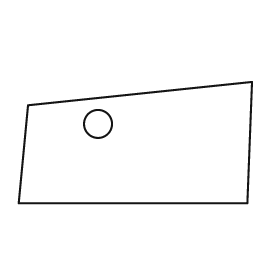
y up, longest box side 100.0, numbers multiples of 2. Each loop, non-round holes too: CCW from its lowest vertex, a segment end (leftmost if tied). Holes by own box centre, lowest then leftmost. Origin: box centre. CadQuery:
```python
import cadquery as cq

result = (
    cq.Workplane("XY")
    .moveTo(-50.0, -26.0)
    .lineTo(48.0, -26.0)
    .lineTo(50.0, 26.0)
    .lineTo(-46.0, 16.0)
    .close()
    .moveTo(-16.0, 8.0)
    .circle(6.0)
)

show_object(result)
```